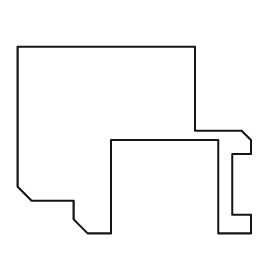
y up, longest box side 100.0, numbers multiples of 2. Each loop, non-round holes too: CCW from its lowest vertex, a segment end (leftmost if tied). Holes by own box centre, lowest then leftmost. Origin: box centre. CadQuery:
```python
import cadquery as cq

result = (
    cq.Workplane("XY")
    .moveTo(-20.0, -40.0)
    .lineTo(-10.0, -40.0)
    .lineTo(-10.0, 0.0)
    .lineTo(36.0, 0.0)
    .lineTo(36.0, -40.0)
    .lineTo(50.0, -40.0)
    .lineTo(50.0, -32.0)
    .lineTo(42.0, -32.0)
    .lineTo(42.0, -6.0)
    .lineTo(50.0, -6.0)
    .lineTo(50.0, 0.0)
    .lineTo(46.0, 4.0)
    .lineTo(26.0, 4.0)
    .lineTo(26.0, 40.0)
    .lineTo(-50.0, 40.0)
    .lineTo(-50.0, -20.0)
    .lineTo(-44.0, -26.0)
    .lineTo(-26.0, -26.0)
    .lineTo(-26.0, -34.0)
    .close()
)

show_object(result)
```